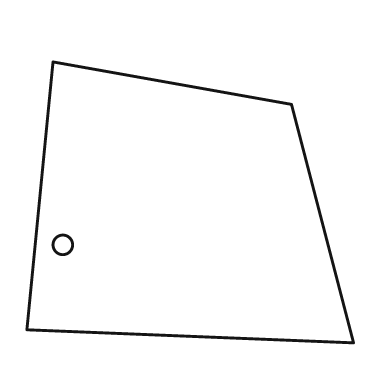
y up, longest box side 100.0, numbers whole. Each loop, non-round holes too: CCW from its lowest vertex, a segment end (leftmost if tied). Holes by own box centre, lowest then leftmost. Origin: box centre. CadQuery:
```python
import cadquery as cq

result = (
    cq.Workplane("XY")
    .moveTo(50.0, -43.0)
    .lineTo(31.0, 30.0)
    .lineTo(-42.0, 43.0)
    .lineTo(-50.0, -39.0)
    .close()
    .moveTo(-39.0, -13.0)
    .circle(3.0)
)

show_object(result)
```